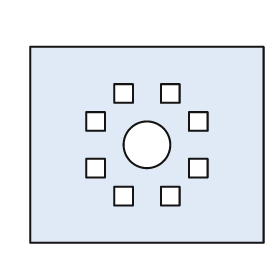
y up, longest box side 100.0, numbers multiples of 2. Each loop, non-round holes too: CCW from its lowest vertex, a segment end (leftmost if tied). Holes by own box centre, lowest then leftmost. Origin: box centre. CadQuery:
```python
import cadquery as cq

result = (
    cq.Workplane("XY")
    .moveTo(-50.0, -42.0)
    .lineTo(50.0, -42.0)
    .lineTo(50.0, 42.0)
    .lineTo(-50.0, 42.0)
    .close()
    .moveTo(-14.0, -26.0)
    .lineTo(-6.0, -26.0)
    .lineTo(-6.0, -18.0)
    .lineTo(-14.0, -18.0)
    .close()
    .moveTo(6.0, -26.0)
    .lineTo(14.0, -26.0)
    .lineTo(14.0, -18.0)
    .lineTo(6.0, -18.0)
    .close()
    .moveTo(-26.0, -14.0)
    .lineTo(-18.0, -14.0)
    .lineTo(-18.0, -6.0)
    .lineTo(-26.0, -6.0)
    .close()
    .moveTo(18.0, -14.0)
    .lineTo(26.0, -14.0)
    .lineTo(26.0, -6.0)
    .lineTo(18.0, -6.0)
    .close()
    .moveTo(0.0, 0.0)
    .circle(10.0)
    .moveTo(-26.0, 6.0)
    .lineTo(-18.0, 6.0)
    .lineTo(-18.0, 14.0)
    .lineTo(-26.0, 14.0)
    .close()
    .moveTo(18.0, 6.0)
    .lineTo(26.0, 6.0)
    .lineTo(26.0, 14.0)
    .lineTo(18.0, 14.0)
    .close()
    .moveTo(-14.0, 18.0)
    .lineTo(-6.0, 18.0)
    .lineTo(-6.0, 26.0)
    .lineTo(-14.0, 26.0)
    .close()
    .moveTo(6.0, 18.0)
    .lineTo(14.0, 18.0)
    .lineTo(14.0, 26.0)
    .lineTo(6.0, 26.0)
    .close()
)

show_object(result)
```